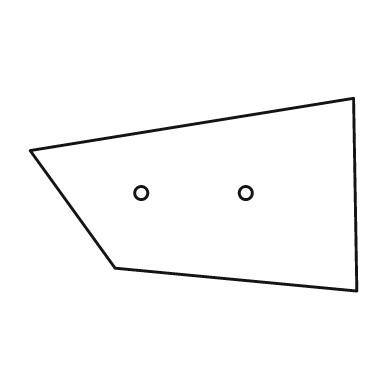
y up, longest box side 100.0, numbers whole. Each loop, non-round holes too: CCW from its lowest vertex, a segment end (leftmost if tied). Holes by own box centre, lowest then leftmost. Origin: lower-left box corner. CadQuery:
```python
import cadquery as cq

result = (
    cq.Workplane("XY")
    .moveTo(100.0, 0.0)
    .lineTo(99.0, 59.0)
    .lineTo(0.0, 43.0)
    .lineTo(26.0, 7.0)
    .close()
    .moveTo(34.0, 30.0)
    .circle(2.0)
    .moveTo(66.0, 30.0)
    .circle(2.0)
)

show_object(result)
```